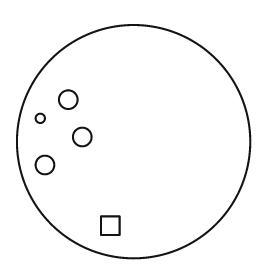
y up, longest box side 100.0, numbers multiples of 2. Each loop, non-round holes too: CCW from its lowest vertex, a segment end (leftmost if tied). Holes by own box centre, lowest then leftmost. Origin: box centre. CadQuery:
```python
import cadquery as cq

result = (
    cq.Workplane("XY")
    .moveTo(0.0, 0.0)
    .circle(50.0)
    .moveTo(-14.0, -40.0)
    .lineTo(-6.0, -40.0)
    .lineTo(-6.0, -32.0)
    .lineTo(-14.0, -32.0)
    .close()
    .moveTo(-38.0, -10.0)
    .circle(4.0)
    .moveTo(-22.0, 2.0)
    .circle(4.0)
    .moveTo(-40.0, 10.0)
    .circle(2.0)
    .moveTo(-28.0, 18.0)
    .circle(4.0)
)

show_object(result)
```